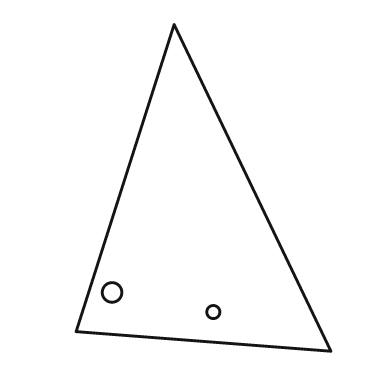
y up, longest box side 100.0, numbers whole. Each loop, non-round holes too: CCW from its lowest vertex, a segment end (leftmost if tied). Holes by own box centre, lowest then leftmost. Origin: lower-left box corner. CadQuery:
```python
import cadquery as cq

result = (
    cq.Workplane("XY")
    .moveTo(78.0, 0.0)
    .lineTo(30.0, 100.0)
    .lineTo(0.0, 6.0)
    .close()
    .moveTo(42.0, 12.0)
    .circle(2.0)
    .moveTo(11.0, 18.0)
    .circle(3.0)
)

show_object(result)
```